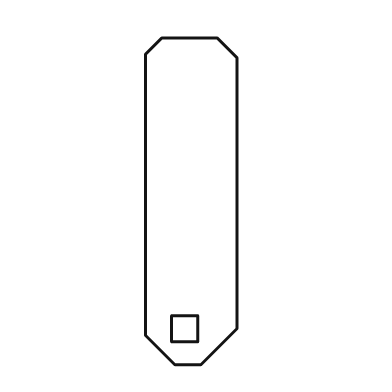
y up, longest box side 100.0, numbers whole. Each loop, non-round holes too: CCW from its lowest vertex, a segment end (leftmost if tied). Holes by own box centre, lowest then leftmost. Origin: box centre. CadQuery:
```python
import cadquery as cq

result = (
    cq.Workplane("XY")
    .moveTo(-5.0, -50.0)
    .lineTo(3.0, -50.0)
    .lineTo(14.0, -39.0)
    .lineTo(14.0, 44.0)
    .lineTo(8.0, 50.0)
    .lineTo(-9.0, 50.0)
    .lineTo(-14.0, 45.0)
    .lineTo(-14.0, -41.0)
    .close()
    .moveTo(-6.0, -43.0)
    .lineTo(2.0, -43.0)
    .lineTo(2.0, -35.0)
    .lineTo(-6.0, -35.0)
    .close()
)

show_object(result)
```